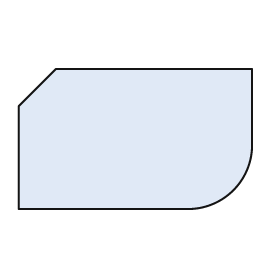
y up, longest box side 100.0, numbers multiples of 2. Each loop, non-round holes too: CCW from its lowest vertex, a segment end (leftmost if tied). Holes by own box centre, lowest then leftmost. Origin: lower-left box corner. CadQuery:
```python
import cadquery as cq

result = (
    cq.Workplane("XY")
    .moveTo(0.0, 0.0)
    .lineTo(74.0, 0.0)
    .threePointArc((92.0, 8.0), (100.0, 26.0))
    .lineTo(100.0, 60.0)
    .lineTo(16.0, 60.0)
    .lineTo(0.0, 44.0)
    .close()
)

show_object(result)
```